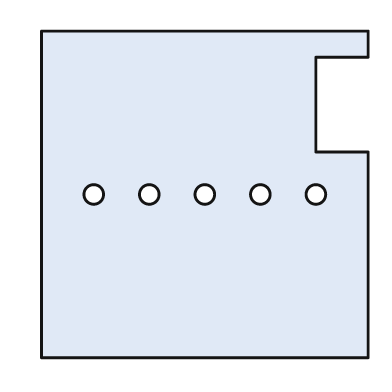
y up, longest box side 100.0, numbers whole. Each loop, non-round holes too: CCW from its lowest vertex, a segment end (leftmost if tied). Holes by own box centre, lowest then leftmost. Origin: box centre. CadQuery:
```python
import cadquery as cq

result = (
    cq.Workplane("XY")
    .moveTo(-50.0, -50.0)
    .lineTo(50.0, -50.0)
    .lineTo(50.0, 13.0)
    .lineTo(34.0, 13.0)
    .lineTo(34.0, 42.0)
    .lineTo(50.0, 42.0)
    .lineTo(50.0, 50.0)
    .lineTo(-50.0, 50.0)
    .close()
    .moveTo(-34.0, 0.0)
    .circle(3.0)
    .moveTo(-17.0, 0.0)
    .circle(3.0)
    .moveTo(0.0, 0.0)
    .circle(3.0)
    .moveTo(17.0, 0.0)
    .circle(3.0)
    .moveTo(34.0, 0.0)
    .circle(3.0)
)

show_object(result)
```